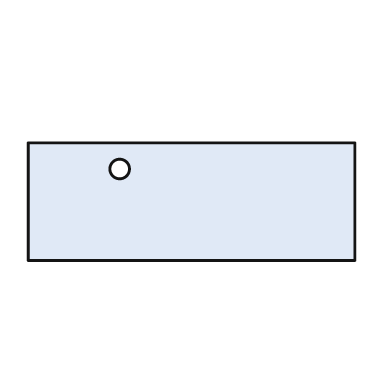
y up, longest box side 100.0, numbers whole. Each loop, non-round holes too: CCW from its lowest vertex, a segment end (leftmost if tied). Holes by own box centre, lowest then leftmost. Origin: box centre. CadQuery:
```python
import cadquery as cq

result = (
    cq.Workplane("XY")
    .moveTo(-50.0, -18.0)
    .lineTo(50.0, -18.0)
    .lineTo(50.0, 18.0)
    .lineTo(-50.0, 18.0)
    .close()
    .moveTo(-22.0, 10.0)
    .circle(3.0)
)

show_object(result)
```